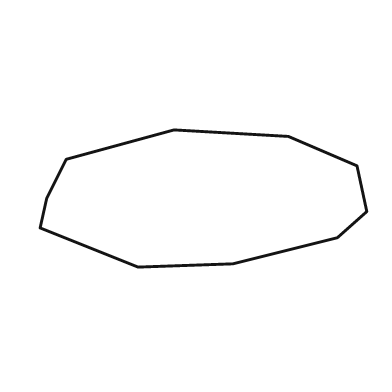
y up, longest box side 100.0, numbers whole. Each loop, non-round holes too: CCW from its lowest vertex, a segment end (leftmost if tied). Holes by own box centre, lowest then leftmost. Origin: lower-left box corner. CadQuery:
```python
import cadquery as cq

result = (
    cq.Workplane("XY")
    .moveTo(30.0, 0.0)
    .lineTo(59.0, 1.0)
    .lineTo(91.0, 9.0)
    .lineTo(100.0, 17.0)
    .lineTo(97.0, 31.0)
    .lineTo(76.0, 40.0)
    .lineTo(41.0, 42.0)
    .lineTo(8.0, 33.0)
    .lineTo(2.0, 21.0)
    .lineTo(0.0, 12.0)
    .close()
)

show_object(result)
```